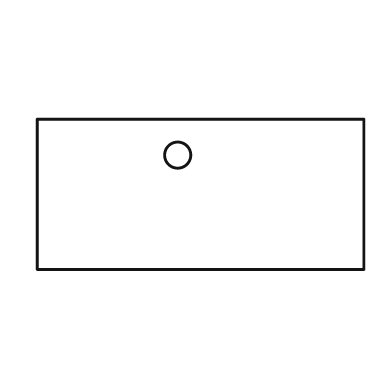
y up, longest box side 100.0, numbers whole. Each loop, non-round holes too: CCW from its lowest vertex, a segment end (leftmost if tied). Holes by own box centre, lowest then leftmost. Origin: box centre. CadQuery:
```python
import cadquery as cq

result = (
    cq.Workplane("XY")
    .moveTo(-50.0, -23.0)
    .lineTo(50.0, -23.0)
    .lineTo(50.0, 23.0)
    .lineTo(-50.0, 23.0)
    .close()
    .moveTo(-7.0, 12.0)
    .circle(4.0)
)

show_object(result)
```